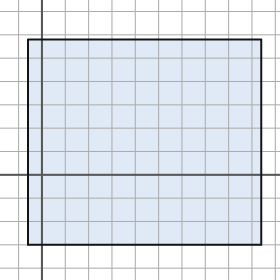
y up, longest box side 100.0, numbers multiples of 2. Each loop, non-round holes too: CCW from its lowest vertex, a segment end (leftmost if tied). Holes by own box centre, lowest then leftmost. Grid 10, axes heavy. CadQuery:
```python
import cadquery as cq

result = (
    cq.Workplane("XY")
    .moveTo(-6.0, -30.0)
    .lineTo(94.0, -30.0)
    .lineTo(94.0, 58.0)
    .lineTo(-6.0, 58.0)
    .close()
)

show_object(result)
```